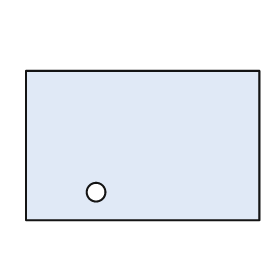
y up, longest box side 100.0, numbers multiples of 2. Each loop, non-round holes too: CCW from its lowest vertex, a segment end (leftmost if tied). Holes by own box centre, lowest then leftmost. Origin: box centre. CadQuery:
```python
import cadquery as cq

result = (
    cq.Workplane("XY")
    .moveTo(-50.0, -32.0)
    .lineTo(50.0, -32.0)
    .lineTo(50.0, 32.0)
    .lineTo(-50.0, 32.0)
    .close()
    .moveTo(-20.0, -20.0)
    .circle(4.0)
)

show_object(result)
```